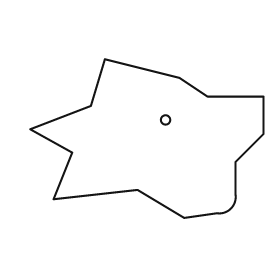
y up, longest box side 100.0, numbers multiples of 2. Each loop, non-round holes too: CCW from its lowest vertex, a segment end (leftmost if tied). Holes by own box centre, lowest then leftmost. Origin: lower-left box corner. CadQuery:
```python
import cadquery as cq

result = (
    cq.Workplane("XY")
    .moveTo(66.0, 0.0)
    .lineTo(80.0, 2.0)
    .threePointArc((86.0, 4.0), (88.0, 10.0))
    .lineTo(88.0, 24.0)
    .lineTo(100.0, 36.0)
    .lineTo(100.0, 52.0)
    .lineTo(76.0, 52.0)
    .lineTo(64.0, 60.0)
    .lineTo(32.0, 68.0)
    .lineTo(26.0, 48.0)
    .lineTo(0.0, 38.0)
    .lineTo(18.0, 28.0)
    .lineTo(10.0, 8.0)
    .lineTo(46.0, 12.0)
    .close()
    .moveTo(58.0, 42.0)
    .circle(2.0)
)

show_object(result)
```